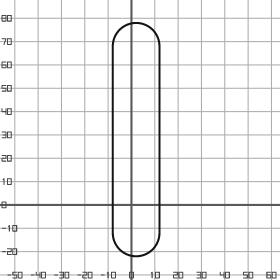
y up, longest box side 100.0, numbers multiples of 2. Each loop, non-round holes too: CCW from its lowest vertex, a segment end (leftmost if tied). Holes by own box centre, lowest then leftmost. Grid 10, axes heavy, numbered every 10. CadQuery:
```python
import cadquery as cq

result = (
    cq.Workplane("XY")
    .moveTo(-8.0, -12.0)
    .threePointArc((2.0, -22.0), (12.0, -12.0))
    .lineTo(12.0, 68.0)
    .threePointArc((2.0, 78.0), (-8.0, 68.0))
    .close()
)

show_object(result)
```